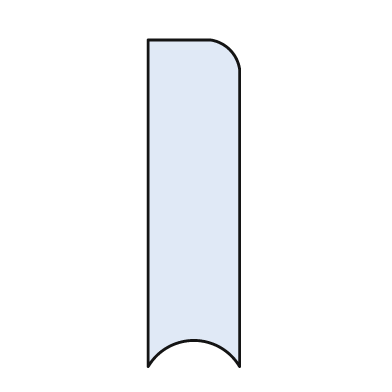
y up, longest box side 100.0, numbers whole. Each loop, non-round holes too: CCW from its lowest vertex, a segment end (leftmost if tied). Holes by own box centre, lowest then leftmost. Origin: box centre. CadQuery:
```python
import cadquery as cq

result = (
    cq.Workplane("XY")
    .moveTo(-14.0, -50.0)
    .threePointArc((0.0, -42.0), (14.0, -50.0))
    .lineTo(14.0, 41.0)
    .threePointArc((11.0, 47.0), (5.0, 50.0))
    .lineTo(-14.0, 50.0)
    .close()
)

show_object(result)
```